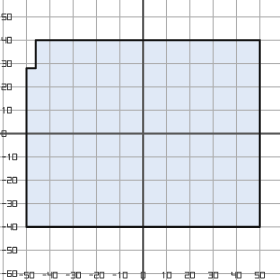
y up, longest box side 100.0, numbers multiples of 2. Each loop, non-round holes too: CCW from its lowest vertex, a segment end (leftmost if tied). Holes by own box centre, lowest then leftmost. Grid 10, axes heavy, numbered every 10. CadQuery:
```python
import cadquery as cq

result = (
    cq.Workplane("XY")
    .moveTo(-50.0, -40.0)
    .lineTo(50.0, -40.0)
    .lineTo(50.0, 40.0)
    .lineTo(-46.0, 40.0)
    .lineTo(-46.0, 28.0)
    .lineTo(-50.0, 28.0)
    .close()
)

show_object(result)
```